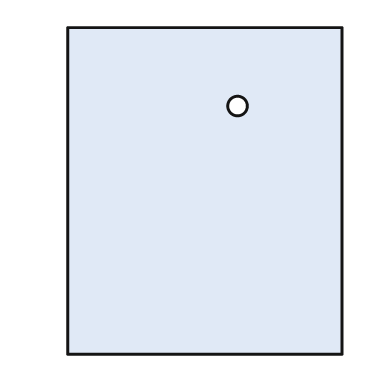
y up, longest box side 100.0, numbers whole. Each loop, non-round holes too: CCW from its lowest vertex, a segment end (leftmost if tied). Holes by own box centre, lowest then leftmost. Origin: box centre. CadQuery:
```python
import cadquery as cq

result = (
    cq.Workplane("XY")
    .moveTo(-42.0, -50.0)
    .lineTo(42.0, -50.0)
    .lineTo(42.0, 50.0)
    .lineTo(-42.0, 50.0)
    .close()
    .moveTo(10.0, 26.0)
    .circle(3.0)
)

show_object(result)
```